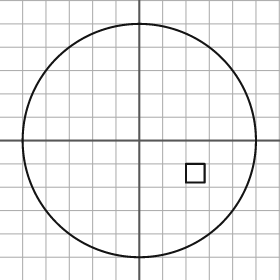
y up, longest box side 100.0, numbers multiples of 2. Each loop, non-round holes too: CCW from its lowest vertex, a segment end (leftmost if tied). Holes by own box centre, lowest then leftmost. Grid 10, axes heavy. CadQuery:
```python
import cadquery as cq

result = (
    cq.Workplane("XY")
    .moveTo(0.0, 0.0)
    .circle(50.0)
    .moveTo(20.0, -18.0)
    .lineTo(28.0, -18.0)
    .lineTo(28.0, -10.0)
    .lineTo(20.0, -10.0)
    .close()
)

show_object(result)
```